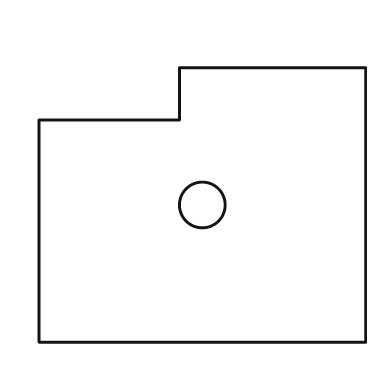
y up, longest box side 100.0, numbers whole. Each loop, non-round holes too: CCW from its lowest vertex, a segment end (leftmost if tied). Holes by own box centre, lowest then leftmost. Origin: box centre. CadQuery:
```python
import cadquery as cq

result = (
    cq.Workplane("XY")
    .moveTo(-50.0, -42.0)
    .lineTo(50.0, -42.0)
    .lineTo(50.0, 42.0)
    .lineTo(-7.0, 42.0)
    .lineTo(-7.0, 26.0)
    .lineTo(-50.0, 26.0)
    .close()
    .moveTo(0.0, 0.0)
    .circle(7.0)
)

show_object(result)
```